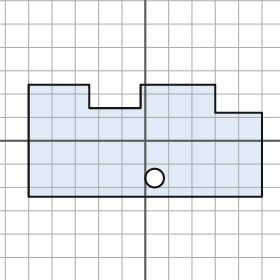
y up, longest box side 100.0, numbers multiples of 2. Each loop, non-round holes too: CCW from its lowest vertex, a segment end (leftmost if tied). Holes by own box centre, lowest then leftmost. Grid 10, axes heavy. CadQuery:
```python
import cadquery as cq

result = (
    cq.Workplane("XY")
    .moveTo(-50.0, -24.0)
    .lineTo(50.0, -24.0)
    .lineTo(50.0, 12.0)
    .lineTo(30.0, 12.0)
    .lineTo(30.0, 24.0)
    .lineTo(-2.0, 24.0)
    .lineTo(-2.0, 14.0)
    .lineTo(-24.0, 14.0)
    .lineTo(-24.0, 24.0)
    .lineTo(-50.0, 24.0)
    .close()
    .moveTo(4.0, -16.0)
    .circle(4.0)
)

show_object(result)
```